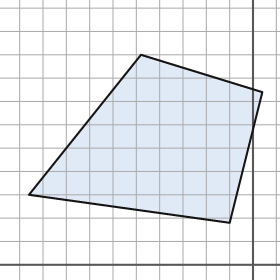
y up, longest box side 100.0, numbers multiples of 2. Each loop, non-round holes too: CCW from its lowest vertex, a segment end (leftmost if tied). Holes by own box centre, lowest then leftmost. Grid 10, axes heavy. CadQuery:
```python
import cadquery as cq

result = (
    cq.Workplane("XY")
    .moveTo(-10.0, 18.0)
    .lineTo(4.0, 74.0)
    .lineTo(-48.0, 90.0)
    .lineTo(-96.0, 30.0)
    .close()
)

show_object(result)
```